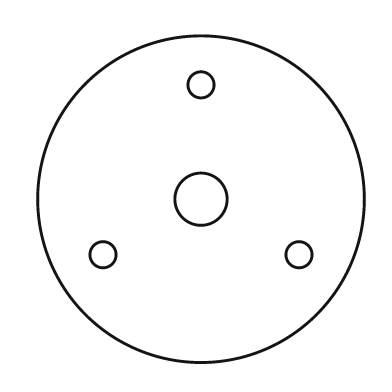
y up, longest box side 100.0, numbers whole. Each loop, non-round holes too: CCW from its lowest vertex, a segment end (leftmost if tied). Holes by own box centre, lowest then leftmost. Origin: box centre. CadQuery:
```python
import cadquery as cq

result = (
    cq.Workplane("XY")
    .moveTo(0.0, 0.0)
    .circle(50.0)
    .moveTo(-30.0, -17.0)
    .circle(4.0)
    .moveTo(30.0, -17.0)
    .circle(4.0)
    .moveTo(0.0, 0.0)
    .circle(8.0)
    .moveTo(0.0, 35.0)
    .circle(4.0)
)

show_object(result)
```